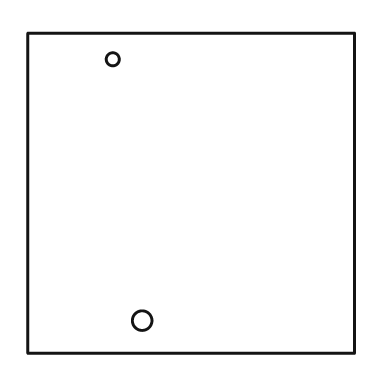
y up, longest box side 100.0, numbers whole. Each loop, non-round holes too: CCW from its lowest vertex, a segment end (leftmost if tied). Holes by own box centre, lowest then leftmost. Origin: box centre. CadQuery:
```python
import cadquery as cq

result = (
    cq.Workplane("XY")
    .moveTo(-50.0, -49.0)
    .lineTo(50.0, -49.0)
    .lineTo(50.0, 49.0)
    .lineTo(-50.0, 49.0)
    .close()
    .moveTo(-15.0, -39.0)
    .circle(3.0)
    .moveTo(-24.0, 41.0)
    .circle(2.0)
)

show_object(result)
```